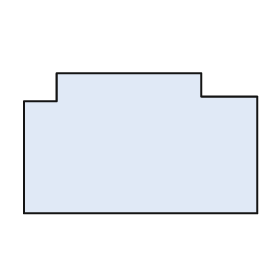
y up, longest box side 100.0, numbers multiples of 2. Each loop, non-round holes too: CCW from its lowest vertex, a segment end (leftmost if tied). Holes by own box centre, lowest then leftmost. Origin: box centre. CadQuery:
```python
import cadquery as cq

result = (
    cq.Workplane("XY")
    .moveTo(-50.0, -30.0)
    .lineTo(50.0, -30.0)
    .lineTo(50.0, 20.0)
    .lineTo(26.0, 20.0)
    .lineTo(26.0, 30.0)
    .lineTo(-36.0, 30.0)
    .lineTo(-36.0, 18.0)
    .lineTo(-50.0, 18.0)
    .close()
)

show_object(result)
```